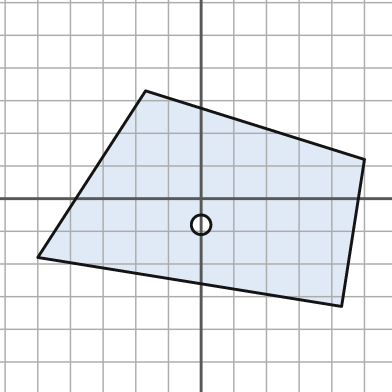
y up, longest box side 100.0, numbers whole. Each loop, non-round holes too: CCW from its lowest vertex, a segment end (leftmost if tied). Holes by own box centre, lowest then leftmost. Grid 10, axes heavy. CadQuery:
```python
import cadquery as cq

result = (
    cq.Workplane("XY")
    .moveTo(43.0, -33.0)
    .lineTo(50.0, 12.0)
    .lineTo(-17.0, 33.0)
    .lineTo(-50.0, -18.0)
    .close()
    .moveTo(0.0, -8.0)
    .circle(3.0)
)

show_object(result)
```